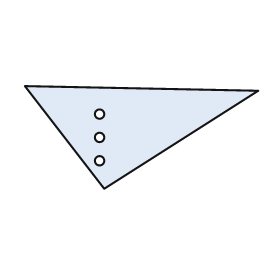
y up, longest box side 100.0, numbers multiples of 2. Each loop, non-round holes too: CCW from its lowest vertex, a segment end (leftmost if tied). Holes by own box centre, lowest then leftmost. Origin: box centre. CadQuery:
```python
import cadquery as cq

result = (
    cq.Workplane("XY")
    .moveTo(-16.0, -22.0)
    .lineTo(50.0, 20.0)
    .lineTo(-50.0, 22.0)
    .close()
    .moveTo(-18.0, -10.0)
    .circle(2.0)
    .moveTo(-18.0, 0.0)
    .circle(2.0)
    .moveTo(-18.0, 10.0)
    .circle(2.0)
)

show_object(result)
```